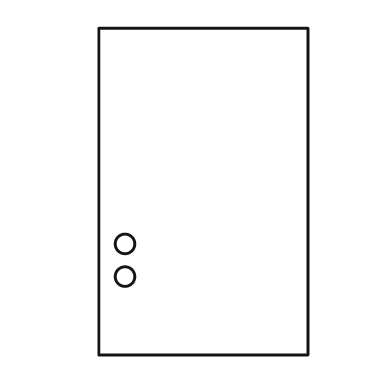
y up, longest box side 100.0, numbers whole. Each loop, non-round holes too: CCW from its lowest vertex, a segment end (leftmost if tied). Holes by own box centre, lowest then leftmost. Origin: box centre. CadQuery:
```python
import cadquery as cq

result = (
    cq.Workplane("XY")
    .moveTo(-32.0, -50.0)
    .lineTo(32.0, -50.0)
    .lineTo(32.0, 50.0)
    .lineTo(-32.0, 50.0)
    .close()
    .moveTo(-24.0, -26.0)
    .circle(3.0)
    .moveTo(-24.0, -16.0)
    .circle(3.0)
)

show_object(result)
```